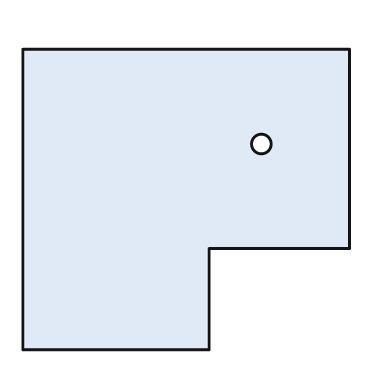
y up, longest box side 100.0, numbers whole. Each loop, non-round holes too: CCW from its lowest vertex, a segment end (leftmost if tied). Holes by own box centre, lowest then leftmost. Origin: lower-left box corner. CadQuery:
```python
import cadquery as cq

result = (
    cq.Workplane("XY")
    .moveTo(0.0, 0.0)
    .lineTo(57.0, 0.0)
    .lineTo(57.0, 31.0)
    .lineTo(100.0, 31.0)
    .lineTo(100.0, 92.0)
    .lineTo(0.0, 92.0)
    .close()
    .moveTo(73.0, 63.0)
    .circle(3.0)
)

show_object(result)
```